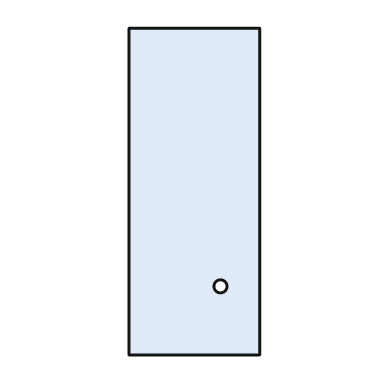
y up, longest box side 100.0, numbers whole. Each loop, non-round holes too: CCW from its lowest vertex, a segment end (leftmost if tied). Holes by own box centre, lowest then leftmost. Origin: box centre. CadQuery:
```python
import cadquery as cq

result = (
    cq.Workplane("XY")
    .moveTo(-20.0, -50.0)
    .lineTo(20.0, -50.0)
    .lineTo(20.0, 50.0)
    .lineTo(-20.0, 50.0)
    .close()
    .moveTo(8.0, -29.0)
    .circle(2.0)
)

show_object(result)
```